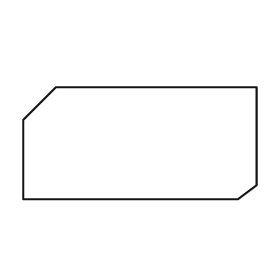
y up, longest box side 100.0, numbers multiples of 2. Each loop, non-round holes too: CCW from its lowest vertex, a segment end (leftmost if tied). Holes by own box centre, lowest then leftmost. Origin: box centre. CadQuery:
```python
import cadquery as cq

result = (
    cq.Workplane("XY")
    .moveTo(-50.0, -24.0)
    .lineTo(42.0, -24.0)
    .lineTo(50.0, -18.0)
    .lineTo(50.0, 24.0)
    .lineTo(-36.0, 24.0)
    .lineTo(-50.0, 10.0)
    .close()
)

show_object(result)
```